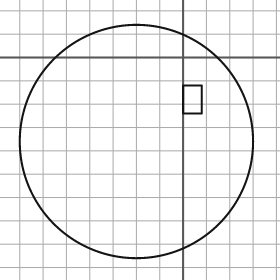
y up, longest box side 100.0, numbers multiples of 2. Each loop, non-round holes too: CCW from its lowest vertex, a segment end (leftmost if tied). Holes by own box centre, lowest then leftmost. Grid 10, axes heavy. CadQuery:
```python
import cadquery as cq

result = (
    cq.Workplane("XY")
    .moveTo(-20.0, -36.0)
    .circle(50.0)
    .moveTo(0.0, -24.0)
    .lineTo(8.0, -24.0)
    .lineTo(8.0, -12.0)
    .lineTo(0.0, -12.0)
    .close()
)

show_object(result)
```